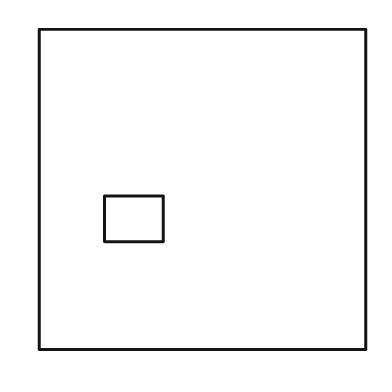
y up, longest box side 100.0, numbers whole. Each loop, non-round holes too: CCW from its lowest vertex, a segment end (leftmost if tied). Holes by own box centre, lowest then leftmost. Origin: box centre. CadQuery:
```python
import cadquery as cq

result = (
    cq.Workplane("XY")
    .moveTo(-50.0, -49.0)
    .lineTo(50.0, -49.0)
    .lineTo(50.0, 49.0)
    .lineTo(-50.0, 49.0)
    .close()
    .moveTo(-30.0, -16.0)
    .lineTo(-12.0, -16.0)
    .lineTo(-12.0, -2.0)
    .lineTo(-30.0, -2.0)
    .close()
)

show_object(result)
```